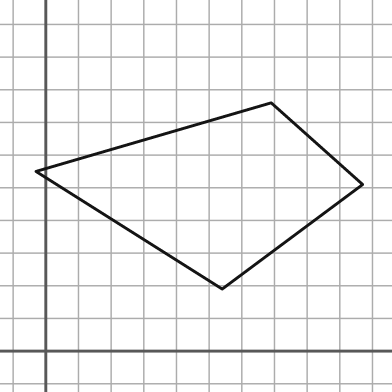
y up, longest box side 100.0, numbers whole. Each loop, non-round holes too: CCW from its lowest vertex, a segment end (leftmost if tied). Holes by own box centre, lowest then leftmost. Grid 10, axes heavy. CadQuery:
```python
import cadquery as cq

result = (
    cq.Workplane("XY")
    .moveTo(54.0, 19.0)
    .lineTo(97.0, 51.0)
    .lineTo(69.0, 76.0)
    .lineTo(-3.0, 55.0)
    .close()
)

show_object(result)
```